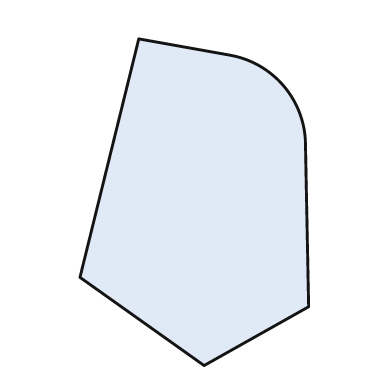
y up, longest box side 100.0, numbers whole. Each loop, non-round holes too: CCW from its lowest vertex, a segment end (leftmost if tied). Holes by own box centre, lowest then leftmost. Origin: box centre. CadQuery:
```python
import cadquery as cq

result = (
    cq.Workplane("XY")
    .moveTo(3.0, -50.0)
    .lineTo(35.0, -32.0)
    .lineTo(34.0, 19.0)
    .threePointArc((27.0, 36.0), (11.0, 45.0))
    .lineTo(-17.0, 50.0)
    .lineTo(-35.0, -23.0)
    .close()
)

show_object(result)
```